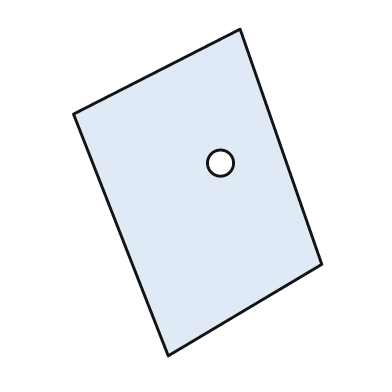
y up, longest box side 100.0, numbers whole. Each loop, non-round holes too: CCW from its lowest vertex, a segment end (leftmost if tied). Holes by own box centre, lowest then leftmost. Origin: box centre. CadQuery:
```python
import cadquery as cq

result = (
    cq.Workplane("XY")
    .moveTo(-9.0, -50.0)
    .lineTo(38.0, -22.0)
    .lineTo(13.0, 50.0)
    .lineTo(-38.0, 24.0)
    .close()
    .moveTo(7.0, 9.0)
    .circle(4.0)
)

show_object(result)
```